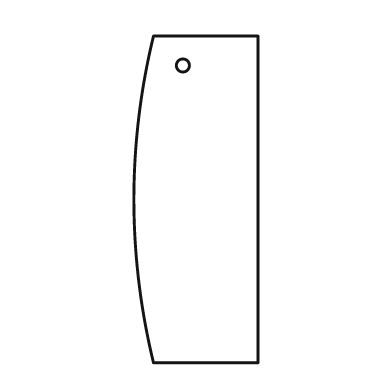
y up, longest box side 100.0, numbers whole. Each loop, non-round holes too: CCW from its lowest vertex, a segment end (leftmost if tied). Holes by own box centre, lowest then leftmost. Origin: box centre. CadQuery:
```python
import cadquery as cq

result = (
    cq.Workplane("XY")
    .moveTo(-13.0, -50.0)
    .lineTo(19.0, -50.0)
    .lineTo(19.0, 50.0)
    .lineTo(-13.0, 50.0)
    .threePointArc((-19.0, 0.0), (-13.0, -50.0))
    .close()
    .moveTo(-4.0, 41.0)
    .circle(2.0)
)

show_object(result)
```